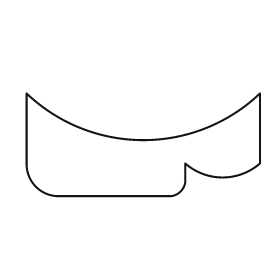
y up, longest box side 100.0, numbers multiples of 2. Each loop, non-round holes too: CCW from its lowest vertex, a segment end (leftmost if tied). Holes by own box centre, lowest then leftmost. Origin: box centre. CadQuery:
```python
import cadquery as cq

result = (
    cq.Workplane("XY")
    .moveTo(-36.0, -22.0)
    .lineTo(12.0, -22.0)
    .threePointArc((16.0, -20.0), (18.0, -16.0))
    .lineTo(18.0, -8.0)
    .threePointArc((34.0, -14.0), (50.0, -8.0))
    .lineTo(50.0, 22.0)
    .threePointArc((0.0, 2.0), (-50.0, 22.0))
    .lineTo(-50.0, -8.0)
    .threePointArc((-46.0, -18.0), (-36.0, -22.0))
    .close()
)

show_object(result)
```